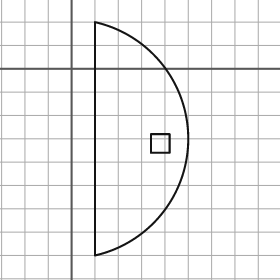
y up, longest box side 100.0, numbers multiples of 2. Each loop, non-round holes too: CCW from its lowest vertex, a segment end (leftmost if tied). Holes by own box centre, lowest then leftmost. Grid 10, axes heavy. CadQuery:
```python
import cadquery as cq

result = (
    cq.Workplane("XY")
    .moveTo(10.0, -80.0)
    .threePointArc((50.0, -30.0), (10.0, 20.0))
    .close()
    .moveTo(34.0, -36.0)
    .lineTo(42.0, -36.0)
    .lineTo(42.0, -28.0)
    .lineTo(34.0, -28.0)
    .close()
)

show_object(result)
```